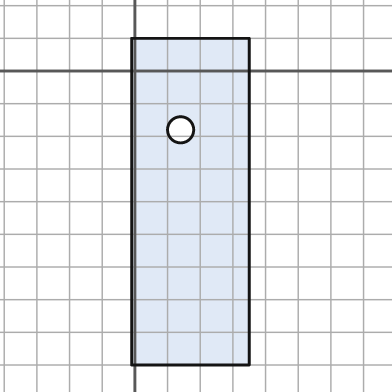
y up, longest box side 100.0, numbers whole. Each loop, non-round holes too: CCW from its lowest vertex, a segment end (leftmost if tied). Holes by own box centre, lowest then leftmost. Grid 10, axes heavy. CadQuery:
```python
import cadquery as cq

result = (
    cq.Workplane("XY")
    .moveTo(-1.0, -90.0)
    .lineTo(35.0, -90.0)
    .lineTo(35.0, 10.0)
    .lineTo(-1.0, 10.0)
    .close()
    .moveTo(14.0, -18.0)
    .circle(4.0)
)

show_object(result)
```